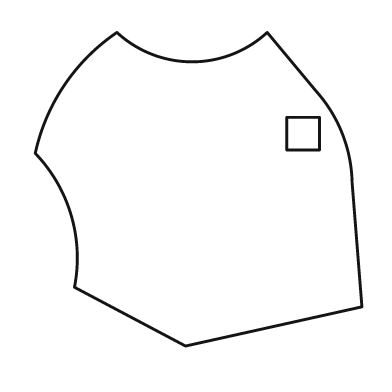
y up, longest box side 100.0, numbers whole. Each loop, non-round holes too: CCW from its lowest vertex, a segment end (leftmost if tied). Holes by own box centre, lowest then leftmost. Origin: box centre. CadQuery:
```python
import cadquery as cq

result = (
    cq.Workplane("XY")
    .moveTo(-4.0, -48.0)
    .lineTo(50.0, -36.0)
    .lineTo(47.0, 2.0)
    .threePointArc((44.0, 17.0), (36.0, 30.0))
    .lineTo(21.0, 48.0)
    .threePointArc((-2.0, 39.0), (-25.0, 48.0))
    .threePointArc((-41.0, 32.0), (-50.0, 11.0))
    .threePointArc((-39.0, -8.0), (-38.0, -30.0))
    .close()
    .moveTo(27.0, 12.0)
    .lineTo(37.0, 12.0)
    .lineTo(37.0, 22.0)
    .lineTo(27.0, 22.0)
    .close()
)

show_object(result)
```